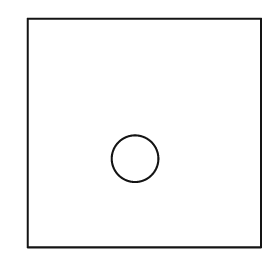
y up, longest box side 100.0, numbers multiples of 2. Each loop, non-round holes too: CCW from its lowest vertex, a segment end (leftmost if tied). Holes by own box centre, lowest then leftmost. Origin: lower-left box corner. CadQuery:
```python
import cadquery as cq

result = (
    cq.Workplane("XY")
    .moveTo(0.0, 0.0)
    .lineTo(100.0, 0.0)
    .lineTo(100.0, 98.0)
    .lineTo(0.0, 98.0)
    .close()
    .moveTo(46.0, 38.0)
    .circle(10.0)
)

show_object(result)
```